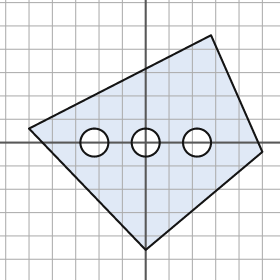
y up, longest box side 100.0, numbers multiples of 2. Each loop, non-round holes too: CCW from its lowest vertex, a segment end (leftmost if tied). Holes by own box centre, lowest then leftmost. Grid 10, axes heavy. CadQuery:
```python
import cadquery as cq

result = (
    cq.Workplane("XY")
    .moveTo(0.0, -46.0)
    .lineTo(50.0, -4.0)
    .lineTo(28.0, 46.0)
    .lineTo(-50.0, 6.0)
    .close()
    .moveTo(-22.0, 0.0)
    .circle(6.0)
    .moveTo(0.0, 0.0)
    .circle(6.0)
    .moveTo(22.0, 0.0)
    .circle(6.0)
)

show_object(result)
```